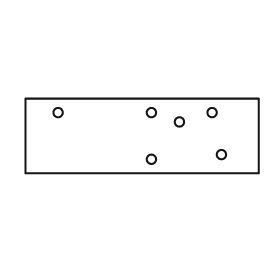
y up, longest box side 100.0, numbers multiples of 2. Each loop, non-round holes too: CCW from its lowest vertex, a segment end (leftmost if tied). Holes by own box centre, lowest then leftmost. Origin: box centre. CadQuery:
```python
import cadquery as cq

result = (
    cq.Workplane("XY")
    .moveTo(-50.0, -16.0)
    .lineTo(50.0, -16.0)
    .lineTo(50.0, 16.0)
    .lineTo(-50.0, 16.0)
    .close()
    .moveTo(4.0, -10.0)
    .circle(2.0)
    .moveTo(34.0, -8.0)
    .circle(2.0)
    .moveTo(16.0, 6.0)
    .circle(2.0)
    .moveTo(-36.0, 10.0)
    .circle(2.0)
    .moveTo(4.0, 10.0)
    .circle(2.0)
    .moveTo(30.0, 10.0)
    .circle(2.0)
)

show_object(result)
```